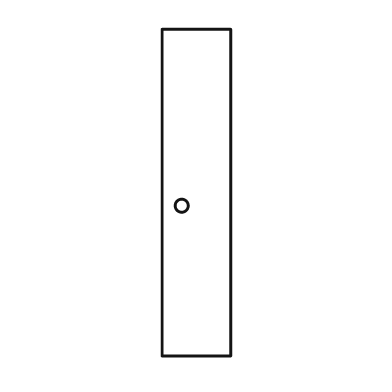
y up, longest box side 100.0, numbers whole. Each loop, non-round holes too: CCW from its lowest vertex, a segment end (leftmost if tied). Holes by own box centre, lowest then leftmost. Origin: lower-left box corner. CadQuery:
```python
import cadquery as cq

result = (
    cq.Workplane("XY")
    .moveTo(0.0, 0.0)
    .lineTo(21.0, 0.0)
    .lineTo(21.0, 100.0)
    .lineTo(0.0, 100.0)
    .close()
    .moveTo(6.0, 46.0)
    .circle(2.0)
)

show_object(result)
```